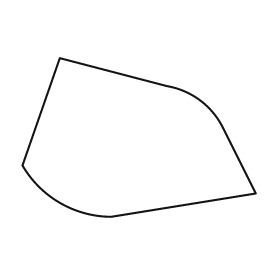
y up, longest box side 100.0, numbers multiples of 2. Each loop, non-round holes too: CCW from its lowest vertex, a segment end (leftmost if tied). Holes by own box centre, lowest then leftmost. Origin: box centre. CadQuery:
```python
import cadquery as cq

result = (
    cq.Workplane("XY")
    .moveTo(-12.0, -34.0)
    .lineTo(50.0, -24.0)
    .lineTo(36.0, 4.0)
    .threePointArc((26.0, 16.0), (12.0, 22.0))
    .lineTo(-34.0, 34.0)
    .lineTo(-50.0, -12.0)
    .threePointArc((-34.0, -28.0), (-12.0, -34.0))
    .close()
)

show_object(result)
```